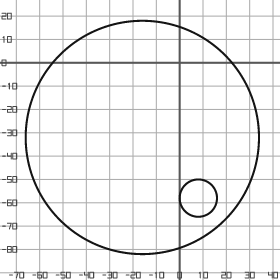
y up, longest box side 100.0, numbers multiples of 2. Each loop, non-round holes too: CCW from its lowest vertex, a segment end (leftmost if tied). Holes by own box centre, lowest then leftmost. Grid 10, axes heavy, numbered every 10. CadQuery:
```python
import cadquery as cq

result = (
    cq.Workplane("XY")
    .moveTo(-16.0, -32.0)
    .circle(50.0)
    .moveTo(8.0, -58.0)
    .circle(8.0)
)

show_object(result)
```